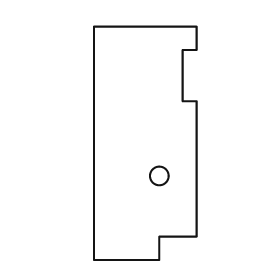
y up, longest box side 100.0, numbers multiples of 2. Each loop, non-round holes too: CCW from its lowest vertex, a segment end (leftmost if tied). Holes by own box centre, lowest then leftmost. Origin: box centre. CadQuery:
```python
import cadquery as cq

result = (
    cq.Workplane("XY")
    .moveTo(-22.0, -50.0)
    .lineTo(6.0, -50.0)
    .lineTo(6.0, -40.0)
    .lineTo(22.0, -40.0)
    .lineTo(22.0, 18.0)
    .lineTo(16.0, 18.0)
    .lineTo(16.0, 40.0)
    .lineTo(22.0, 40.0)
    .lineTo(22.0, 50.0)
    .lineTo(-22.0, 50.0)
    .close()
    .moveTo(6.0, -14.0)
    .circle(4.0)
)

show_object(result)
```